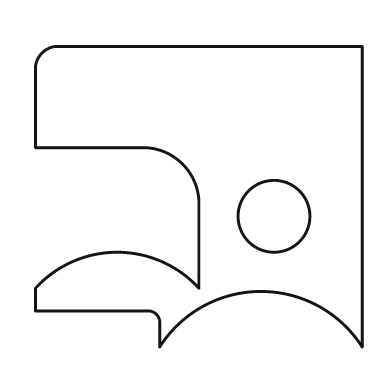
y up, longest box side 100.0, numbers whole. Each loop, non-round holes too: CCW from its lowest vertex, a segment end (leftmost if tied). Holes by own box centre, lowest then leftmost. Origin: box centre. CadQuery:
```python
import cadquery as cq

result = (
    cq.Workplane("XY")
    .moveTo(-12.0, -46.0)
    .threePointArc((19.0, -29.0), (50.0, -46.0))
    .lineTo(50.0, 46.0)
    .lineTo(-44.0, 46.0)
    .threePointArc((-48.0, 44.0), (-50.0, 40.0))
    .lineTo(-50.0, 15.0)
    .lineTo(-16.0, 15.0)
    .threePointArc((-5.0, 10.0), (0.0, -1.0))
    .lineTo(0.0, -28.0)
    .threePointArc((-25.0, -17.0), (-50.0, -28.0))
    .lineTo(-50.0, -35.0)
    .lineTo(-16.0, -35.0)
    .threePointArc((-13.0, -36.0), (-12.0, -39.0))
    .close()
    .moveTo(23.0, -6.0)
    .circle(11.0)
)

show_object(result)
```